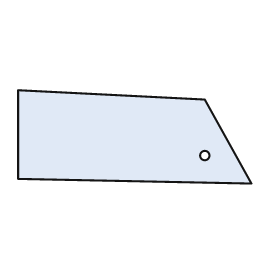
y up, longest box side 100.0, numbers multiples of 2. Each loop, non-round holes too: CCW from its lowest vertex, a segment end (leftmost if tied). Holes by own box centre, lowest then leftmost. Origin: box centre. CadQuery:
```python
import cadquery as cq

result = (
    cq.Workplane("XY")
    .moveTo(50.0, -20.0)
    .lineTo(30.0, 16.0)
    .lineTo(-50.0, 20.0)
    .lineTo(-50.0, -18.0)
    .close()
    .moveTo(30.0, -8.0)
    .circle(2.0)
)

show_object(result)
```